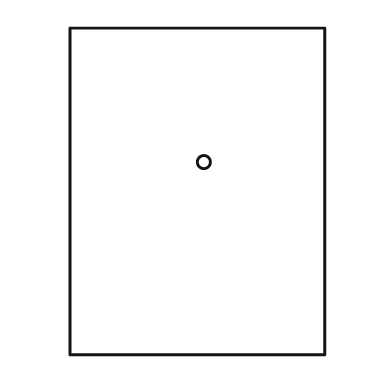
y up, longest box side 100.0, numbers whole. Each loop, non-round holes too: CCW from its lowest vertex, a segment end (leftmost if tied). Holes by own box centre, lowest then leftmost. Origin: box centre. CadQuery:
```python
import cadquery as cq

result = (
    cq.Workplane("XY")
    .moveTo(-39.0, -50.0)
    .lineTo(39.0, -50.0)
    .lineTo(39.0, 50.0)
    .lineTo(-39.0, 50.0)
    .close()
    .moveTo(2.0, 9.0)
    .circle(2.0)
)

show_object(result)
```